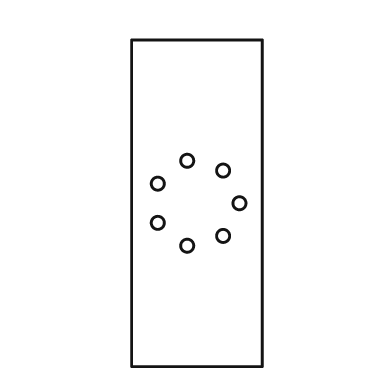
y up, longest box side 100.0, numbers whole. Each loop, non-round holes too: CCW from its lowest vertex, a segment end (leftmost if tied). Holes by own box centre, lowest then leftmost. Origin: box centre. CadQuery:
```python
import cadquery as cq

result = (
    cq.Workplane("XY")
    .moveTo(-20.0, -50.0)
    .lineTo(20.0, -50.0)
    .lineTo(20.0, 50.0)
    .lineTo(-20.0, 50.0)
    .close()
    .moveTo(-3.0, -13.0)
    .circle(2.0)
    .moveTo(8.0, -10.0)
    .circle(2.0)
    .moveTo(-12.0, -6.0)
    .circle(2.0)
    .moveTo(13.0, 0.0)
    .circle(2.0)
    .moveTo(-12.0, 6.0)
    .circle(2.0)
    .moveTo(8.0, 10.0)
    .circle(2.0)
    .moveTo(-3.0, 13.0)
    .circle(2.0)
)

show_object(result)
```